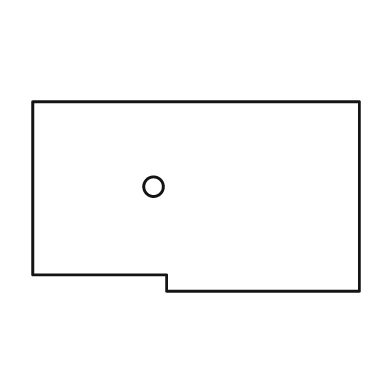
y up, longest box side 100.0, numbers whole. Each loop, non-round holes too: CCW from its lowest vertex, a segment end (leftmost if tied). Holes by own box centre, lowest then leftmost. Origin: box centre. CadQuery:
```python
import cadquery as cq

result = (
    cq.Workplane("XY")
    .moveTo(-9.0, -29.0)
    .lineTo(50.0, -29.0)
    .lineTo(50.0, 29.0)
    .lineTo(-50.0, 29.0)
    .lineTo(-50.0, -24.0)
    .lineTo(-9.0, -24.0)
    .close()
    .moveTo(-13.0, 3.0)
    .circle(3.0)
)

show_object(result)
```